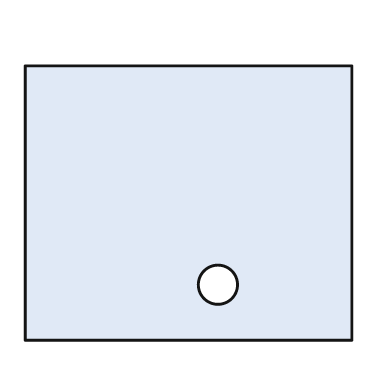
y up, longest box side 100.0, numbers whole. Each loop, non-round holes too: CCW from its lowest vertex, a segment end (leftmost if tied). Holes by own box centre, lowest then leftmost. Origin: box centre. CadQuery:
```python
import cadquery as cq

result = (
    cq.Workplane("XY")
    .moveTo(-50.0, -42.0)
    .lineTo(50.0, -42.0)
    .lineTo(50.0, 42.0)
    .lineTo(-50.0, 42.0)
    .close()
    .moveTo(9.0, -25.0)
    .circle(6.0)
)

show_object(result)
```